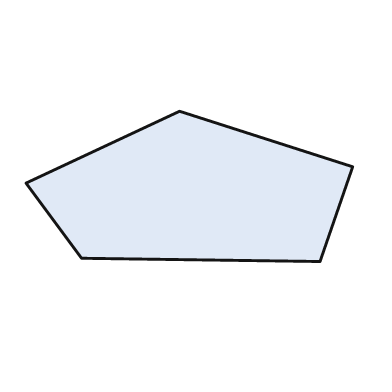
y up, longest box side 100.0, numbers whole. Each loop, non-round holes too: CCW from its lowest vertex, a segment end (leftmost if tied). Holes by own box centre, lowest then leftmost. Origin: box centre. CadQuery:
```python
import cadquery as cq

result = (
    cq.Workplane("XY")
    .moveTo(40.0, -23.0)
    .lineTo(50.0, 6.0)
    .lineTo(-3.0, 23.0)
    .lineTo(-50.0, 1.0)
    .lineTo(-33.0, -22.0)
    .close()
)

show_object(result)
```